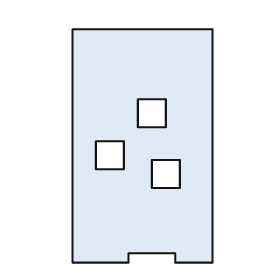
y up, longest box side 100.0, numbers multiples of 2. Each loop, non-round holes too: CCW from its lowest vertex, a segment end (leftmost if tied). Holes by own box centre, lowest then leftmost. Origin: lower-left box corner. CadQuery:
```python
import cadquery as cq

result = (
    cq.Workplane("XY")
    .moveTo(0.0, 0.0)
    .lineTo(24.0, 0.0)
    .lineTo(24.0, 4.0)
    .lineTo(44.0, 4.0)
    .lineTo(44.0, 0.0)
    .lineTo(60.0, 0.0)
    .lineTo(60.0, 100.0)
    .lineTo(0.0, 100.0)
    .close()
    .moveTo(34.0, 32.0)
    .lineTo(46.0, 32.0)
    .lineTo(46.0, 44.0)
    .lineTo(34.0, 44.0)
    .close()
    .moveTo(10.0, 40.0)
    .lineTo(22.0, 40.0)
    .lineTo(22.0, 52.0)
    .lineTo(10.0, 52.0)
    .close()
    .moveTo(28.0, 58.0)
    .lineTo(40.0, 58.0)
    .lineTo(40.0, 70.0)
    .lineTo(28.0, 70.0)
    .close()
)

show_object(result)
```